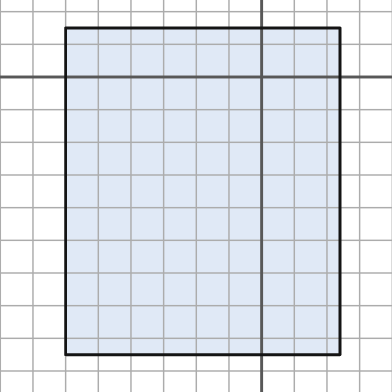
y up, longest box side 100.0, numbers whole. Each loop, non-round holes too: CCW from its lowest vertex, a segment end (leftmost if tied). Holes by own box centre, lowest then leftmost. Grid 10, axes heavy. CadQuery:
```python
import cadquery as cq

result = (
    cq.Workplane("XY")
    .moveTo(-60.0, -85.0)
    .lineTo(24.0, -85.0)
    .lineTo(24.0, 15.0)
    .lineTo(-60.0, 15.0)
    .close()
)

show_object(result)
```